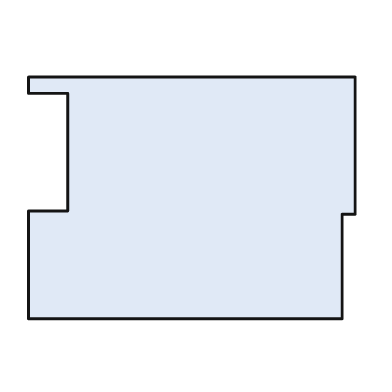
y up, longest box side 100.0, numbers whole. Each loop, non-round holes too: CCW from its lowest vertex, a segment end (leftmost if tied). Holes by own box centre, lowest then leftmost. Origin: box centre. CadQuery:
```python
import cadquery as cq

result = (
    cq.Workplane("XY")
    .moveTo(-50.0, -37.0)
    .lineTo(46.0, -37.0)
    .lineTo(46.0, -5.0)
    .lineTo(50.0, -5.0)
    .lineTo(50.0, 37.0)
    .lineTo(-50.0, 37.0)
    .lineTo(-50.0, 32.0)
    .lineTo(-38.0, 32.0)
    .lineTo(-38.0, -4.0)
    .lineTo(-50.0, -4.0)
    .close()
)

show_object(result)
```